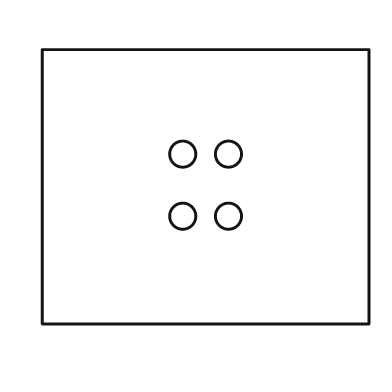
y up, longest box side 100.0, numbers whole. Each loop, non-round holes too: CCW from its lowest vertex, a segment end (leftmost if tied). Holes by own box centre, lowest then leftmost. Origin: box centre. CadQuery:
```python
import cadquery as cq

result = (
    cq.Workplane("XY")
    .moveTo(-50.0, -42.0)
    .lineTo(50.0, -42.0)
    .lineTo(50.0, 42.0)
    .lineTo(-50.0, 42.0)
    .close()
    .moveTo(-7.0, -9.0)
    .circle(4.0)
    .moveTo(7.0, -9.0)
    .circle(4.0)
    .moveTo(-7.0, 10.0)
    .circle(4.0)
    .moveTo(7.0, 10.0)
    .circle(4.0)
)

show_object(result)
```